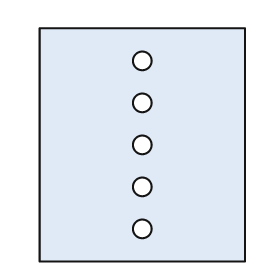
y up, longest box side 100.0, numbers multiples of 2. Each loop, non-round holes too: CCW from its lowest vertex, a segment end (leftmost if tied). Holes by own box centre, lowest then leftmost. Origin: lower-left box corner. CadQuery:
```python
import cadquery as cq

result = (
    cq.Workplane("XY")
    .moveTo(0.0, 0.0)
    .lineTo(88.0, 0.0)
    .lineTo(88.0, 100.0)
    .lineTo(0.0, 100.0)
    .close()
    .moveTo(44.0, 14.0)
    .circle(4.0)
    .moveTo(44.0, 32.0)
    .circle(4.0)
    .moveTo(44.0, 50.0)
    .circle(4.0)
    .moveTo(44.0, 68.0)
    .circle(4.0)
    .moveTo(44.0, 86.0)
    .circle(4.0)
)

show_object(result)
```